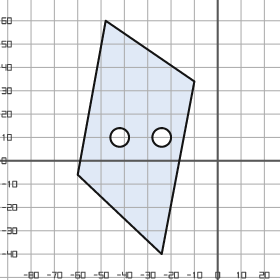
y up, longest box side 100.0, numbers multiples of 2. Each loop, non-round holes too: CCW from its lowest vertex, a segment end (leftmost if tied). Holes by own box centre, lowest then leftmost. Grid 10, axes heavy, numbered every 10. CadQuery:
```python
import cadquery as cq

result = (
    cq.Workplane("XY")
    .moveTo(-24.0, -40.0)
    .lineTo(-10.0, 34.0)
    .lineTo(-48.0, 60.0)
    .lineTo(-60.0, -6.0)
    .close()
    .moveTo(-42.0, 10.0)
    .circle(4.0)
    .moveTo(-24.0, 10.0)
    .circle(4.0)
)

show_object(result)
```